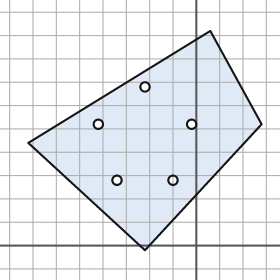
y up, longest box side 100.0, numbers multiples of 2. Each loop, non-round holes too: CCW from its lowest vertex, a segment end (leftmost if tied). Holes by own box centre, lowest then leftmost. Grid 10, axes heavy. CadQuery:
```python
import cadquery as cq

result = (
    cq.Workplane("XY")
    .moveTo(-22.0, -2.0)
    .lineTo(28.0, 52.0)
    .lineTo(6.0, 92.0)
    .lineTo(-72.0, 44.0)
    .close()
    .moveTo(-34.0, 28.0)
    .circle(2.0)
    .moveTo(-10.0, 28.0)
    .circle(2.0)
    .moveTo(-42.0, 52.0)
    .circle(2.0)
    .moveTo(-2.0, 52.0)
    .circle(2.0)
    .moveTo(-22.0, 68.0)
    .circle(2.0)
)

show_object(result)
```